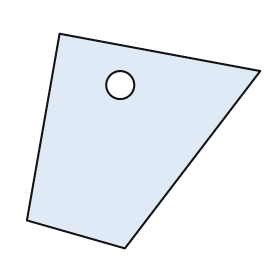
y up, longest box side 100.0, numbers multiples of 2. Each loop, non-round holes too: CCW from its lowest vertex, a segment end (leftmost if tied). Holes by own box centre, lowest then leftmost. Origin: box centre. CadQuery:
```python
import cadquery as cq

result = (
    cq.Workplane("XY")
    .moveTo(-8.0, -46.0)
    .lineTo(50.0, 30.0)
    .lineTo(-36.0, 46.0)
    .lineTo(-50.0, -34.0)
    .close()
    .moveTo(-10.0, 24.0)
    .circle(6.0)
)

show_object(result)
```